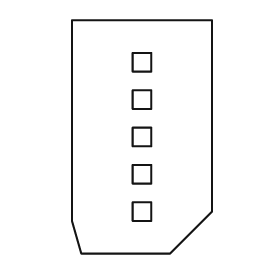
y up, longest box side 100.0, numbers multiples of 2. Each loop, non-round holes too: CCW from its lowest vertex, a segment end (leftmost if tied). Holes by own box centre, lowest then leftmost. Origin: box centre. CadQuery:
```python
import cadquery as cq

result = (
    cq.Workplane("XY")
    .moveTo(-26.0, -50.0)
    .lineTo(12.0, -50.0)
    .lineTo(30.0, -32.0)
    .lineTo(30.0, 50.0)
    .lineTo(-30.0, 50.0)
    .lineTo(-30.0, -36.0)
    .close()
    .moveTo(-4.0, -36.0)
    .lineTo(4.0, -36.0)
    .lineTo(4.0, -28.0)
    .lineTo(-4.0, -28.0)
    .close()
    .moveTo(-4.0, -20.0)
    .lineTo(4.0, -20.0)
    .lineTo(4.0, -12.0)
    .lineTo(-4.0, -12.0)
    .close()
    .moveTo(-4.0, -4.0)
    .lineTo(4.0, -4.0)
    .lineTo(4.0, 4.0)
    .lineTo(-4.0, 4.0)
    .close()
    .moveTo(-4.0, 12.0)
    .lineTo(4.0, 12.0)
    .lineTo(4.0, 20.0)
    .lineTo(-4.0, 20.0)
    .close()
    .moveTo(-4.0, 28.0)
    .lineTo(4.0, 28.0)
    .lineTo(4.0, 36.0)
    .lineTo(-4.0, 36.0)
    .close()
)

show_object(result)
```